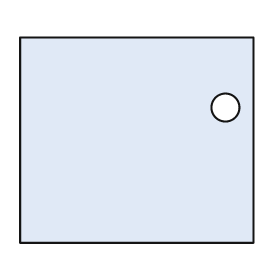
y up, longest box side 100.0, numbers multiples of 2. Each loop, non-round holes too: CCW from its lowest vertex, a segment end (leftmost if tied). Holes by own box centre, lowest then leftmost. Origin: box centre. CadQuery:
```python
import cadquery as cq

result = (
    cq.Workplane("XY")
    .moveTo(-50.0, -44.0)
    .lineTo(50.0, -44.0)
    .lineTo(50.0, 44.0)
    .lineTo(-50.0, 44.0)
    .close()
    .moveTo(38.0, 14.0)
    .circle(6.0)
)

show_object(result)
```